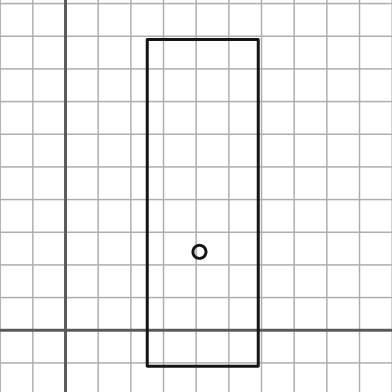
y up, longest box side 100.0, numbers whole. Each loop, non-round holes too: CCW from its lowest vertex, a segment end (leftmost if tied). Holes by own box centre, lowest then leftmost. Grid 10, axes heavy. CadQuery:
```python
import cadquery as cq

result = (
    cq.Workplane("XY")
    .moveTo(25.0, -11.0)
    .lineTo(59.0, -11.0)
    .lineTo(59.0, 89.0)
    .lineTo(25.0, 89.0)
    .close()
    .moveTo(41.0, 24.0)
    .circle(2.0)
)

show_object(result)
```